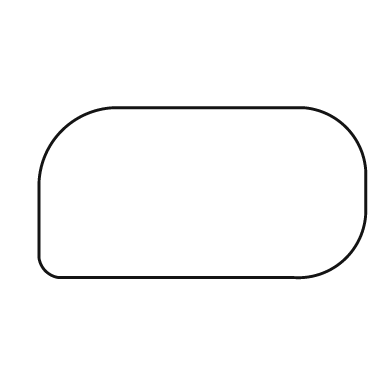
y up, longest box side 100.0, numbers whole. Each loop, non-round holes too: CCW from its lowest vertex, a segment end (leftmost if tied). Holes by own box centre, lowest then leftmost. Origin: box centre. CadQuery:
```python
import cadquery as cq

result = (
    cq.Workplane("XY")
    .moveTo(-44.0, -26.0)
    .lineTo(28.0, -26.0)
    .threePointArc((44.0, -20.0), (50.0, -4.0))
    .lineTo(50.0, 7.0)
    .threePointArc((44.0, 20.0), (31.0, 26.0))
    .lineTo(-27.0, 26.0)
    .threePointArc((-43.0, 19.0), (-50.0, 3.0))
    .lineTo(-50.0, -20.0)
    .threePointArc((-48.0, -24.0), (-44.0, -26.0))
    .close()
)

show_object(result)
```